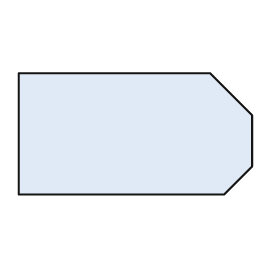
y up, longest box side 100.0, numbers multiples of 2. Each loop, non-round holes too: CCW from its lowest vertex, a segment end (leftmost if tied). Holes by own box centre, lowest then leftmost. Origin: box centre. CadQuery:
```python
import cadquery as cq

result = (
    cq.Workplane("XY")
    .moveTo(-50.0, -26.0)
    .lineTo(38.0, -26.0)
    .lineTo(50.0, -14.0)
    .lineTo(50.0, 8.0)
    .lineTo(32.0, 26.0)
    .lineTo(-50.0, 26.0)
    .close()
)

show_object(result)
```